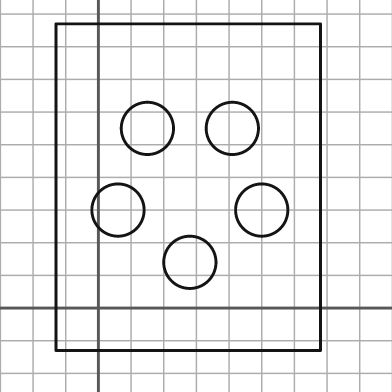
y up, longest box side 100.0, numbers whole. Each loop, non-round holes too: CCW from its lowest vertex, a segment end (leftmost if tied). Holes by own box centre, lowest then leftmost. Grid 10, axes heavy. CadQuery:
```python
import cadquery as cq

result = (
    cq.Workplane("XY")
    .moveTo(-13.0, -13.0)
    .lineTo(68.0, -13.0)
    .lineTo(68.0, 87.0)
    .lineTo(-13.0, 87.0)
    .close()
    .moveTo(28.0, 14.0)
    .circle(8.0)
    .moveTo(6.0, 30.0)
    .circle(8.0)
    .moveTo(50.0, 30.0)
    .circle(8.0)
    .moveTo(15.0, 55.0)
    .circle(8.0)
    .moveTo(41.0, 55.0)
    .circle(8.0)
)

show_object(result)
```